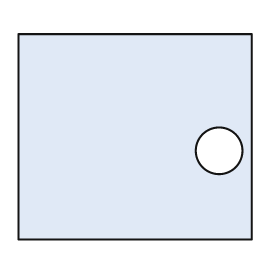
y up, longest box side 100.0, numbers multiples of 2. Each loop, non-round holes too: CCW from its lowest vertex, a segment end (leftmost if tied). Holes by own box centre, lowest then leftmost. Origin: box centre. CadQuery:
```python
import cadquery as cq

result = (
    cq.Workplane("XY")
    .moveTo(-50.0, -44.0)
    .lineTo(50.0, -44.0)
    .lineTo(50.0, 44.0)
    .lineTo(-50.0, 44.0)
    .close()
    .moveTo(36.0, -6.0)
    .circle(10.0)
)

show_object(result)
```